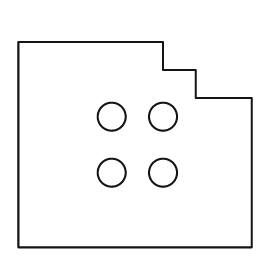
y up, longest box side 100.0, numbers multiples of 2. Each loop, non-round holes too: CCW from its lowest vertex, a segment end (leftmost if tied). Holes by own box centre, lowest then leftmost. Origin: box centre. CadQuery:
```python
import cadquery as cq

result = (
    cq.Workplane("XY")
    .moveTo(-50.0, -44.0)
    .lineTo(50.0, -44.0)
    .lineTo(50.0, 20.0)
    .lineTo(26.0, 20.0)
    .lineTo(26.0, 32.0)
    .lineTo(12.0, 32.0)
    .lineTo(12.0, 44.0)
    .lineTo(-50.0, 44.0)
    .close()
    .moveTo(-10.0, -12.0)
    .circle(6.0)
    .moveTo(12.0, -12.0)
    .circle(6.0)
    .moveTo(-10.0, 12.0)
    .circle(6.0)
    .moveTo(12.0, 12.0)
    .circle(6.0)
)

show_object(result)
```